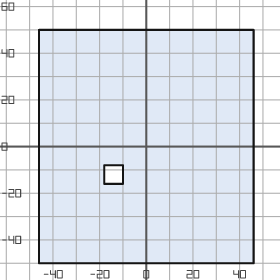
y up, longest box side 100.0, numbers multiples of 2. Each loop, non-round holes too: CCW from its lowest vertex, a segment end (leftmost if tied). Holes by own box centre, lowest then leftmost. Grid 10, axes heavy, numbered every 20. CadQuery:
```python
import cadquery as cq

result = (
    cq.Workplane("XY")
    .moveTo(-46.0, -50.0)
    .lineTo(46.0, -50.0)
    .lineTo(46.0, 50.0)
    .lineTo(-46.0, 50.0)
    .close()
    .moveTo(-18.0, -16.0)
    .lineTo(-10.0, -16.0)
    .lineTo(-10.0, -8.0)
    .lineTo(-18.0, -8.0)
    .close()
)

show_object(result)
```